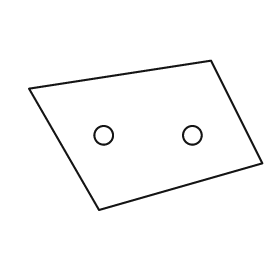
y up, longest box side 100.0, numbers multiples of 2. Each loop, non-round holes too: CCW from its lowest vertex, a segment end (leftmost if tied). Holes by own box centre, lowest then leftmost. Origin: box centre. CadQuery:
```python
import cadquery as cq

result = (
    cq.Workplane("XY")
    .moveTo(-20.0, -32.0)
    .lineTo(50.0, -12.0)
    .lineTo(28.0, 32.0)
    .lineTo(-50.0, 20.0)
    .close()
    .moveTo(-18.0, 0.0)
    .circle(4.0)
    .moveTo(20.0, 0.0)
    .circle(4.0)
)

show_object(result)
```